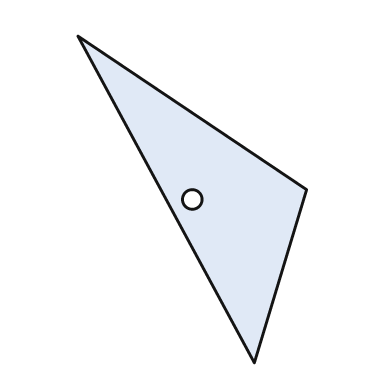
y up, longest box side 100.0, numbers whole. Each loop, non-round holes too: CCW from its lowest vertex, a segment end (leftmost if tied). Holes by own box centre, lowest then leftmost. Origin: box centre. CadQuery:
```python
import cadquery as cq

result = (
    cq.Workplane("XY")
    .moveTo(19.0, -50.0)
    .lineTo(35.0, 3.0)
    .lineTo(-35.0, 50.0)
    .close()
    .moveTo(0.0, 0.0)
    .circle(3.0)
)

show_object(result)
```